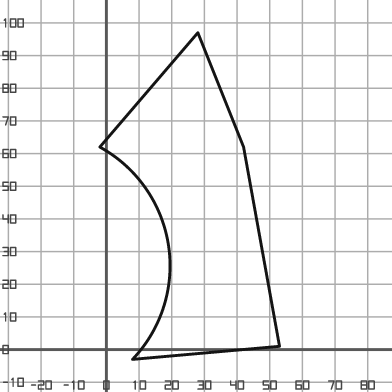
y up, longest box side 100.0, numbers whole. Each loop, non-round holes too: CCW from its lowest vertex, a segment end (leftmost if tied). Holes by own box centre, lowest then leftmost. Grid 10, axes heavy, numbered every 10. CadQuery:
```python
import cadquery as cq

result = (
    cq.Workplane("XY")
    .moveTo(8.0, -3.0)
    .lineTo(53.0, 1.0)
    .lineTo(42.0, 62.0)
    .lineTo(28.0, 97.0)
    .lineTo(-2.0, 62.0)
    .threePointArc((19.0, 32.0), (8.0, -3.0))
    .close()
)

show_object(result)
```